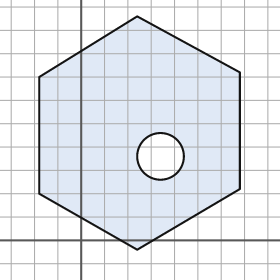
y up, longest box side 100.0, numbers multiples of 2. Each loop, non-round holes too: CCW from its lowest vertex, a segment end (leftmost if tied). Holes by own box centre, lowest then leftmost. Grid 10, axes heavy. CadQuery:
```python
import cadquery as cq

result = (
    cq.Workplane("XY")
    .moveTo(24.0, -4.0)
    .lineTo(68.0, 22.0)
    .lineTo(68.0, 72.0)
    .lineTo(24.0, 96.0)
    .lineTo(-18.0, 70.0)
    .lineTo(-18.0, 20.0)
    .close()
    .moveTo(34.0, 36.0)
    .circle(10.0)
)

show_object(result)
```